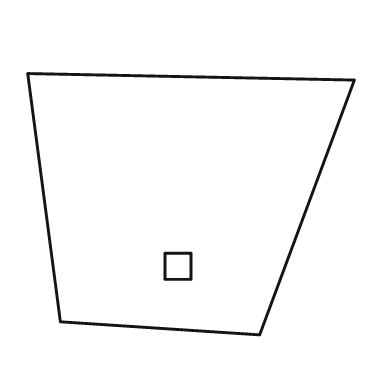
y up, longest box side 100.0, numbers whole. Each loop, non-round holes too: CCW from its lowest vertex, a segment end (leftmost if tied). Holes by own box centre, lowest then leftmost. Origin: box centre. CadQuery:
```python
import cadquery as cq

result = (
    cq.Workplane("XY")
    .moveTo(21.0, -40.0)
    .lineTo(50.0, 38.0)
    .lineTo(-50.0, 40.0)
    .lineTo(-40.0, -36.0)
    .close()
    .moveTo(-8.0, -23.0)
    .lineTo(0.0, -23.0)
    .lineTo(0.0, -15.0)
    .lineTo(-8.0, -15.0)
    .close()
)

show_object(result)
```